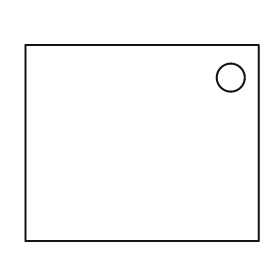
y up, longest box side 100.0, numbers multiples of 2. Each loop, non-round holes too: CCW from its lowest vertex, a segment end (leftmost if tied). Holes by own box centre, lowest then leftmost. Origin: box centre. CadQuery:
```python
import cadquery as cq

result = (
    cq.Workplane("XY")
    .moveTo(-50.0, -42.0)
    .lineTo(50.0, -42.0)
    .lineTo(50.0, 42.0)
    .lineTo(-50.0, 42.0)
    .close()
    .moveTo(38.0, 28.0)
    .circle(6.0)
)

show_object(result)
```